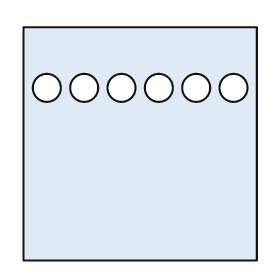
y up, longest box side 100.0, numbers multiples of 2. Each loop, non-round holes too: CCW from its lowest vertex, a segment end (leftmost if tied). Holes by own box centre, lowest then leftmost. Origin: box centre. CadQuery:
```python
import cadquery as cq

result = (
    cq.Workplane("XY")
    .moveTo(-50.0, -50.0)
    .lineTo(50.0, -50.0)
    .lineTo(50.0, 50.0)
    .lineTo(-50.0, 50.0)
    .close()
    .moveTo(-40.0, 24.0)
    .circle(6.0)
    .moveTo(-24.0, 24.0)
    .circle(6.0)
    .moveTo(-8.0, 24.0)
    .circle(6.0)
    .moveTo(8.0, 24.0)
    .circle(6.0)
    .moveTo(24.0, 24.0)
    .circle(6.0)
    .moveTo(40.0, 24.0)
    .circle(6.0)
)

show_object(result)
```